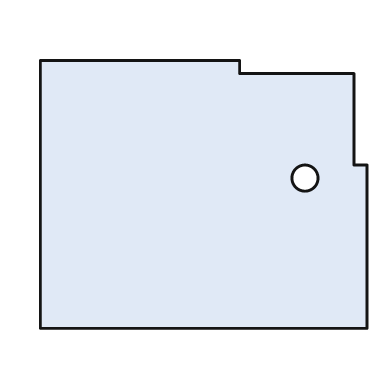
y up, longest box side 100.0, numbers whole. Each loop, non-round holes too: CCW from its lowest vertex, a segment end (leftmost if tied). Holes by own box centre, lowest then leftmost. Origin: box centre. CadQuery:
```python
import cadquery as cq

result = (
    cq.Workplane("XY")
    .moveTo(-50.0, -41.0)
    .lineTo(50.0, -41.0)
    .lineTo(50.0, 9.0)
    .lineTo(46.0, 9.0)
    .lineTo(46.0, 37.0)
    .lineTo(11.0, 37.0)
    .lineTo(11.0, 41.0)
    .lineTo(-50.0, 41.0)
    .close()
    .moveTo(31.0, 5.0)
    .circle(4.0)
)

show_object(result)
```